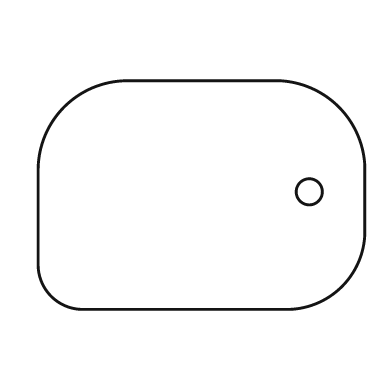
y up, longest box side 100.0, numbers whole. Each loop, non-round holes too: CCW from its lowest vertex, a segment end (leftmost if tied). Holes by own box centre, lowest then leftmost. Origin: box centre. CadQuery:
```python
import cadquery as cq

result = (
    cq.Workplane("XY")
    .moveTo(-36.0, -35.0)
    .lineTo(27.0, -35.0)
    .threePointArc((43.0, -28.0), (50.0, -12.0))
    .lineTo(50.0, 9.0)
    .threePointArc((42.0, 27.0), (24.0, 35.0))
    .lineTo(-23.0, 35.0)
    .threePointArc((-42.0, 27.0), (-50.0, 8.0))
    .lineTo(-50.0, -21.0)
    .threePointArc((-46.0, -31.0), (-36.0, -35.0))
    .close()
    .moveTo(33.0, 1.0)
    .circle(4.0)
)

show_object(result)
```